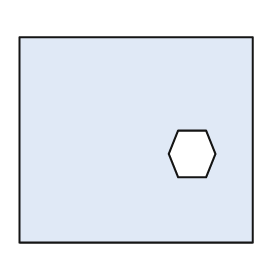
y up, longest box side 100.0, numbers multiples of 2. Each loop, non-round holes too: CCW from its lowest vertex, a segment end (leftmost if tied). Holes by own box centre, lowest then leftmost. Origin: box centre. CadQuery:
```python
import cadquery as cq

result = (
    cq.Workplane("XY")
    .moveTo(-50.0, -44.0)
    .lineTo(50.0, -44.0)
    .lineTo(50.0, 44.0)
    .lineTo(-50.0, 44.0)
    .close()
    .moveTo(18.0, -16.0)
    .lineTo(30.0, -16.0)
    .lineTo(34.0, -6.0)
    .lineTo(30.0, 4.0)
    .lineTo(18.0, 4.0)
    .lineTo(14.0, -6.0)
    .close()
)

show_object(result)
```